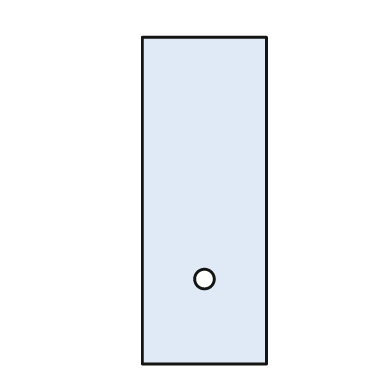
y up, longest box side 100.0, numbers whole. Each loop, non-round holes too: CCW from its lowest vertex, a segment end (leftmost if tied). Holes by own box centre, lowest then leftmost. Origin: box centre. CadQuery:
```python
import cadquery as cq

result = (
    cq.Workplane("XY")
    .moveTo(-19.0, -50.0)
    .lineTo(19.0, -50.0)
    .lineTo(19.0, 50.0)
    .lineTo(-19.0, 50.0)
    .close()
    .moveTo(0.0, -24.0)
    .circle(3.0)
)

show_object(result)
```